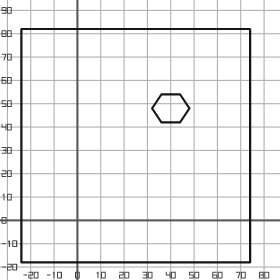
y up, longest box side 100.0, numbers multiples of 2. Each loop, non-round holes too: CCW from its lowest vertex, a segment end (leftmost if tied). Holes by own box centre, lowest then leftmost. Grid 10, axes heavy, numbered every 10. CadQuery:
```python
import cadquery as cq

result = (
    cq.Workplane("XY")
    .moveTo(-24.0, -18.0)
    .lineTo(74.0, -18.0)
    .lineTo(74.0, 82.0)
    .lineTo(-24.0, 82.0)
    .close()
    .moveTo(36.0, 42.0)
    .lineTo(44.0, 42.0)
    .lineTo(48.0, 48.0)
    .lineTo(44.0, 54.0)
    .lineTo(36.0, 54.0)
    .lineTo(32.0, 48.0)
    .close()
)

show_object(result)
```